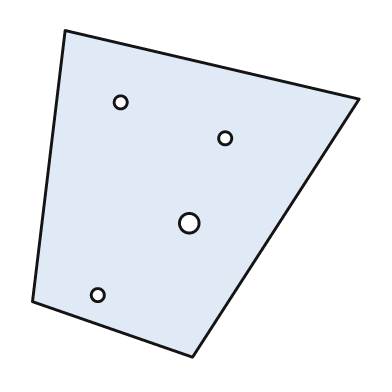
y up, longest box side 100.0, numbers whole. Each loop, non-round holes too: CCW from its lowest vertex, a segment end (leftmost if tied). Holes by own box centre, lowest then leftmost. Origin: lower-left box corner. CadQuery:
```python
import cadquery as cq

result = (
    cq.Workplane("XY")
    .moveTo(49.0, 0.0)
    .lineTo(100.0, 79.0)
    .lineTo(10.0, 100.0)
    .lineTo(0.0, 17.0)
    .close()
    .moveTo(20.0, 19.0)
    .circle(2.0)
    .moveTo(48.0, 41.0)
    .circle(3.0)
    .moveTo(59.0, 67.0)
    .circle(2.0)
    .moveTo(27.0, 78.0)
    .circle(2.0)
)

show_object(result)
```